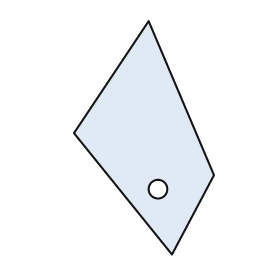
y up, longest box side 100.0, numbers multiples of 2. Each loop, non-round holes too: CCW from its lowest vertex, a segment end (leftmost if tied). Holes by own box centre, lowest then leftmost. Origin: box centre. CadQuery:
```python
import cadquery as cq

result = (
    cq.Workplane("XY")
    .moveTo(12.0, -50.0)
    .lineTo(30.0, -16.0)
    .lineTo(2.0, 50.0)
    .lineTo(-30.0, 2.0)
    .close()
    .moveTo(6.0, -22.0)
    .circle(4.0)
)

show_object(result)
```